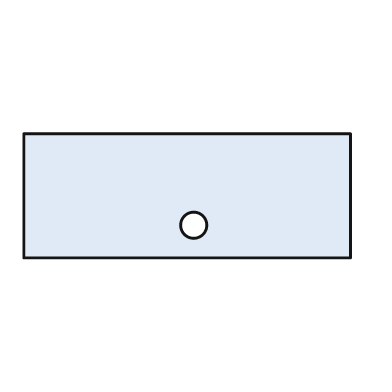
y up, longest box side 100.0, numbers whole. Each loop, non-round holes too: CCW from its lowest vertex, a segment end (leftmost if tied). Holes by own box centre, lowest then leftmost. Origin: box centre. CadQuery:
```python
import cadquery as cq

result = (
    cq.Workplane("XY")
    .moveTo(-50.0, -19.0)
    .lineTo(50.0, -19.0)
    .lineTo(50.0, 19.0)
    .lineTo(-50.0, 19.0)
    .close()
    .moveTo(2.0, -9.0)
    .circle(4.0)
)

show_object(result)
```